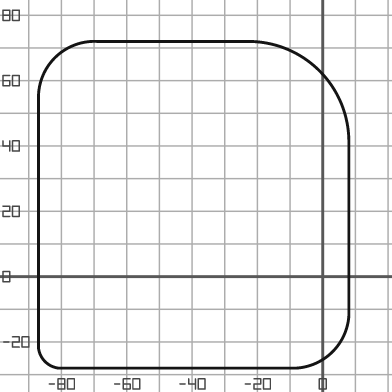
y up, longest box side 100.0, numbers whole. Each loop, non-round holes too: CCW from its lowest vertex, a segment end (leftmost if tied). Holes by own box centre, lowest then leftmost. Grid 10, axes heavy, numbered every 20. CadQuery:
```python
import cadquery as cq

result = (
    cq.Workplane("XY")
    .moveTo(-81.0, -28.0)
    .lineTo(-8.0, -28.0)
    .threePointArc((3.0, -23.0), (8.0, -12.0))
    .lineTo(8.0, 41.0)
    .threePointArc((-1.0, 63.0), (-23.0, 72.0))
    .lineTo(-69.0, 72.0)
    .threePointArc((-82.0, 67.0), (-87.0, 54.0))
    .lineTo(-87.0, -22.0)
    .threePointArc((-85.0, -26.0), (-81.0, -28.0))
    .close()
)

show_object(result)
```